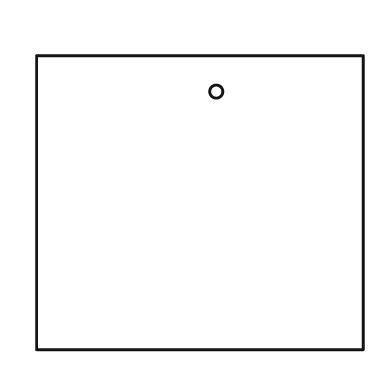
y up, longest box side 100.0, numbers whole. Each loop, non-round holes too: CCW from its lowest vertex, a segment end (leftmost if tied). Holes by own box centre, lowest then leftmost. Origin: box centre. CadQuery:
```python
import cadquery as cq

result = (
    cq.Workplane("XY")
    .moveTo(-50.0, -45.0)
    .lineTo(50.0, -45.0)
    .lineTo(50.0, 45.0)
    .lineTo(-50.0, 45.0)
    .close()
    .moveTo(5.0, 34.0)
    .circle(2.0)
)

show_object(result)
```